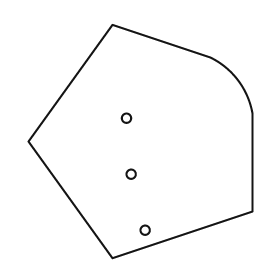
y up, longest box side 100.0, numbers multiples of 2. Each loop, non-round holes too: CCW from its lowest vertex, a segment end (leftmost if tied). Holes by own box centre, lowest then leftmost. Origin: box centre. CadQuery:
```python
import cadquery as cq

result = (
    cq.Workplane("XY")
    .moveTo(-12.0, -50.0)
    .lineTo(48.0, -30.0)
    .lineTo(48.0, 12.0)
    .threePointArc((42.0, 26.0), (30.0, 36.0))
    .lineTo(-12.0, 50.0)
    .lineTo(-48.0, 0.0)
    .close()
    .moveTo(2.0, -38.0)
    .circle(2.0)
    .moveTo(-4.0, -14.0)
    .circle(2.0)
    .moveTo(-6.0, 10.0)
    .circle(2.0)
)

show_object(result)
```